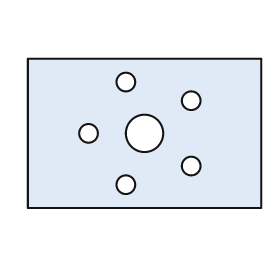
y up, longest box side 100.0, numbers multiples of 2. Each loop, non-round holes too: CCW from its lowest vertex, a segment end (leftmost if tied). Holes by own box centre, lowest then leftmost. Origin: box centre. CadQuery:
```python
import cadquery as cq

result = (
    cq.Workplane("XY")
    .moveTo(-50.0, -32.0)
    .lineTo(50.0, -32.0)
    .lineTo(50.0, 32.0)
    .lineTo(-50.0, 32.0)
    .close()
    .moveTo(-8.0, -22.0)
    .circle(4.0)
    .moveTo(20.0, -14.0)
    .circle(4.0)
    .moveTo(-24.0, 0.0)
    .circle(4.0)
    .moveTo(0.0, 0.0)
    .circle(8.0)
    .moveTo(20.0, 14.0)
    .circle(4.0)
    .moveTo(-8.0, 22.0)
    .circle(4.0)
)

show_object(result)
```